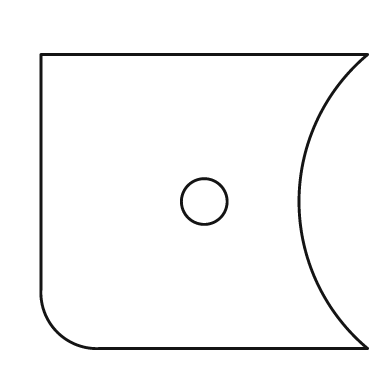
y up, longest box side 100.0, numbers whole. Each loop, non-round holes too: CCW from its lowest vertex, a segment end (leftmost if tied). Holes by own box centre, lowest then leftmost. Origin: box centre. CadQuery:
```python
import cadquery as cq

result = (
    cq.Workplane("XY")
    .moveTo(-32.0, -45.0)
    .lineTo(50.0, -45.0)
    .threePointArc((29.0, 0.0), (50.0, 45.0))
    .lineTo(-50.0, 45.0)
    .lineTo(-50.0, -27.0)
    .threePointArc((-45.0, -40.0), (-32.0, -45.0))
    .close()
    .moveTo(0.0, 0.0)
    .circle(7.0)
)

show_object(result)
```